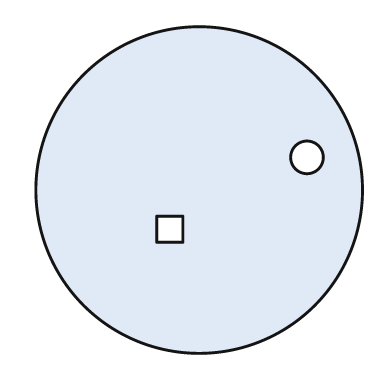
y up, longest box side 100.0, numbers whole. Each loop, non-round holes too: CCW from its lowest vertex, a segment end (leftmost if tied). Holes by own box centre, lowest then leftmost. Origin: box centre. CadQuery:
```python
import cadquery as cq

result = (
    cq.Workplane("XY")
    .moveTo(0.0, 0.0)
    .circle(50.0)
    .moveTo(-13.0, -16.0)
    .lineTo(-5.0, -16.0)
    .lineTo(-5.0, -8.0)
    .lineTo(-13.0, -8.0)
    .close()
    .moveTo(33.0, 10.0)
    .circle(5.0)
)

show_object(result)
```